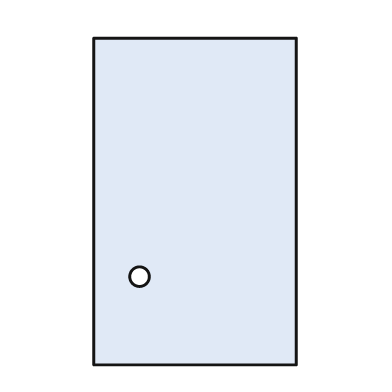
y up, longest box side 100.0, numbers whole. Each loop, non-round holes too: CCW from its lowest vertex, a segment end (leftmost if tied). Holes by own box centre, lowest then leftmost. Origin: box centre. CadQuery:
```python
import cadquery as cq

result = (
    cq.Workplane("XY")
    .moveTo(-31.0, -50.0)
    .lineTo(31.0, -50.0)
    .lineTo(31.0, 50.0)
    .lineTo(-31.0, 50.0)
    .close()
    .moveTo(-17.0, -23.0)
    .circle(3.0)
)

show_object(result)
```